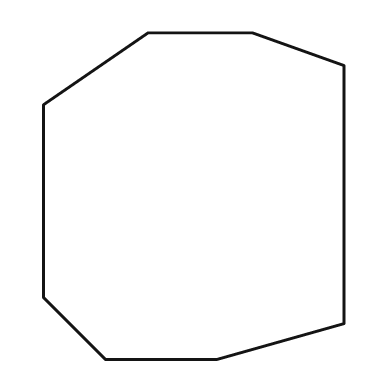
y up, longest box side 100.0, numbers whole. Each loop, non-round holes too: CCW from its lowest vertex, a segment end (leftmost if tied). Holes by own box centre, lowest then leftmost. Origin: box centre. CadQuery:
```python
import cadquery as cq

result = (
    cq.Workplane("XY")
    .moveTo(-27.0, -50.0)
    .lineTo(7.0, -50.0)
    .lineTo(46.0, -39.0)
    .lineTo(46.0, 40.0)
    .lineTo(18.0, 50.0)
    .lineTo(-14.0, 50.0)
    .lineTo(-46.0, 28.0)
    .lineTo(-46.0, -31.0)
    .close()
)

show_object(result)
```